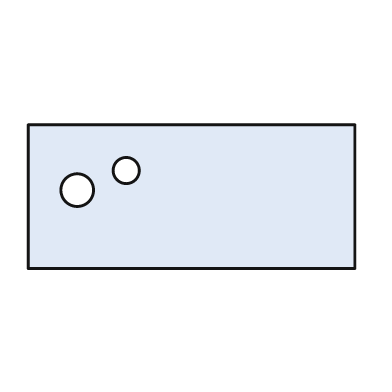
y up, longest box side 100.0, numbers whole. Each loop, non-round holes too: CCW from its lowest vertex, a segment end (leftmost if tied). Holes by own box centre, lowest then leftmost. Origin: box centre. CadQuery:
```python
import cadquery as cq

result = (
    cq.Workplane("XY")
    .moveTo(-50.0, -22.0)
    .lineTo(50.0, -22.0)
    .lineTo(50.0, 22.0)
    .lineTo(-50.0, 22.0)
    .close()
    .moveTo(-35.0, 2.0)
    .circle(5.0)
    .moveTo(-20.0, 8.0)
    .circle(4.0)
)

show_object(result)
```